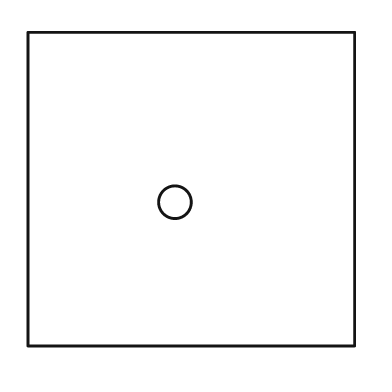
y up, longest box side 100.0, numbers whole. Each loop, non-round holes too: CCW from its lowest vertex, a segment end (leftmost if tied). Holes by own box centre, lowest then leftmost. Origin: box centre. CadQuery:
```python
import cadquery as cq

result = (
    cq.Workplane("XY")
    .moveTo(-50.0, -48.0)
    .lineTo(50.0, -48.0)
    .lineTo(50.0, 48.0)
    .lineTo(-50.0, 48.0)
    .close()
    .moveTo(-5.0, -4.0)
    .circle(5.0)
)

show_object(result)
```